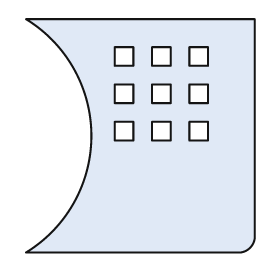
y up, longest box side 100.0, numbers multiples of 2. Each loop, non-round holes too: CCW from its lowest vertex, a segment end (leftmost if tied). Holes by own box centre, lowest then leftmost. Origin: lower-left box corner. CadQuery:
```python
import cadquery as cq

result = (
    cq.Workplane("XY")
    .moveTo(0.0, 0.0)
    .lineTo(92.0, 0.0)
    .threePointArc((96.0, 2.0), (98.0, 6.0))
    .lineTo(98.0, 100.0)
    .lineTo(0.0, 100.0)
    .threePointArc((28.0, 50.0), (0.0, 0.0))
    .close()
    .moveTo(38.0, 48.0)
    .lineTo(46.0, 48.0)
    .lineTo(46.0, 56.0)
    .lineTo(38.0, 56.0)
    .close()
    .moveTo(54.0, 48.0)
    .lineTo(62.0, 48.0)
    .lineTo(62.0, 56.0)
    .lineTo(54.0, 56.0)
    .close()
    .moveTo(70.0, 48.0)
    .lineTo(78.0, 48.0)
    .lineTo(78.0, 56.0)
    .lineTo(70.0, 56.0)
    .close()
    .moveTo(38.0, 64.0)
    .lineTo(46.0, 64.0)
    .lineTo(46.0, 72.0)
    .lineTo(38.0, 72.0)
    .close()
    .moveTo(54.0, 64.0)
    .lineTo(62.0, 64.0)
    .lineTo(62.0, 72.0)
    .lineTo(54.0, 72.0)
    .close()
    .moveTo(70.0, 64.0)
    .lineTo(78.0, 64.0)
    .lineTo(78.0, 72.0)
    .lineTo(70.0, 72.0)
    .close()
    .moveTo(38.0, 80.0)
    .lineTo(46.0, 80.0)
    .lineTo(46.0, 88.0)
    .lineTo(38.0, 88.0)
    .close()
    .moveTo(54.0, 80.0)
    .lineTo(62.0, 80.0)
    .lineTo(62.0, 88.0)
    .lineTo(54.0, 88.0)
    .close()
    .moveTo(70.0, 80.0)
    .lineTo(78.0, 80.0)
    .lineTo(78.0, 88.0)
    .lineTo(70.0, 88.0)
    .close()
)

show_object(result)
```